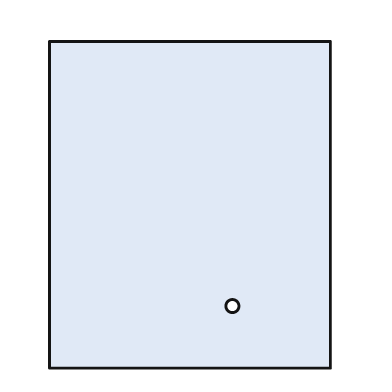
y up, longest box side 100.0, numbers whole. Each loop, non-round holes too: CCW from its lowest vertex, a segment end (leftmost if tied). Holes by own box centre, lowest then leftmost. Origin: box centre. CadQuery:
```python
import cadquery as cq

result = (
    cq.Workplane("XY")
    .moveTo(-43.0, -50.0)
    .lineTo(43.0, -50.0)
    .lineTo(43.0, 50.0)
    .lineTo(-43.0, 50.0)
    .close()
    .moveTo(13.0, -31.0)
    .circle(2.0)
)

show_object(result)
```